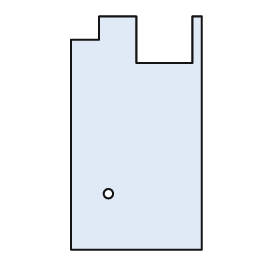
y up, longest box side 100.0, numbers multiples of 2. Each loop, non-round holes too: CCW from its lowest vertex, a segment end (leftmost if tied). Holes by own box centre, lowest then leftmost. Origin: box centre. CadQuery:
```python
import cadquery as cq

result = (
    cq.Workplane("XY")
    .moveTo(-28.0, -50.0)
    .lineTo(28.0, -50.0)
    .lineTo(28.0, 50.0)
    .lineTo(24.0, 50.0)
    .lineTo(24.0, 30.0)
    .lineTo(0.0, 30.0)
    .lineTo(0.0, 50.0)
    .lineTo(-16.0, 50.0)
    .lineTo(-16.0, 40.0)
    .lineTo(-28.0, 40.0)
    .close()
    .moveTo(-12.0, -26.0)
    .circle(2.0)
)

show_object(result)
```